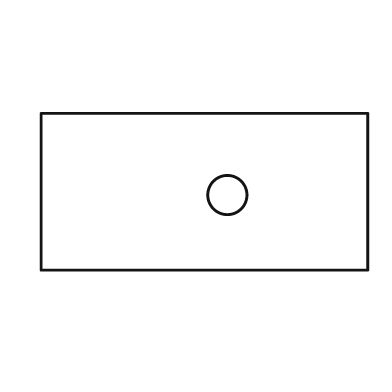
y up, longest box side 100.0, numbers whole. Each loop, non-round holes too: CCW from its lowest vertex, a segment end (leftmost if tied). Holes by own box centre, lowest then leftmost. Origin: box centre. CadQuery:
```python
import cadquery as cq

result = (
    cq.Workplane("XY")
    .moveTo(-50.0, -24.0)
    .lineTo(50.0, -24.0)
    .lineTo(50.0, 24.0)
    .lineTo(-50.0, 24.0)
    .close()
    .moveTo(7.0, -1.0)
    .circle(6.0)
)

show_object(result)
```